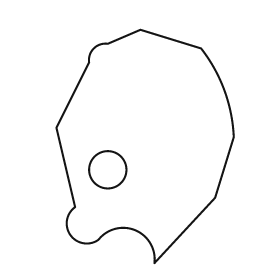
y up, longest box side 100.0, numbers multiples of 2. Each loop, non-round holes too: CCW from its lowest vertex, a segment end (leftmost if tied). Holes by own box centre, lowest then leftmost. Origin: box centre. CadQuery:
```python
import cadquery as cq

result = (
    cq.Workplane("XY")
    .moveTo(4.0, -50.0)
    .lineTo(30.0, -22.0)
    .lineTo(38.0, 4.0)
    .threePointArc((34.0, 24.0), (24.0, 42.0))
    .lineTo(-2.0, 50.0)
    .lineTo(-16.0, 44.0)
    .threePointArc((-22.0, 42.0), (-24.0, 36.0))
    .lineTo(-38.0, 8.0)
    .lineTo(-30.0, -26.0)
    .threePointArc((-32.0, -38.0), (-20.0, -40.0))
    .threePointArc((-4.0, -36.0), (4.0, -50.0))
    .close()
    .moveTo(-16.0, -10.0)
    .circle(8.0)
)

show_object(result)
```